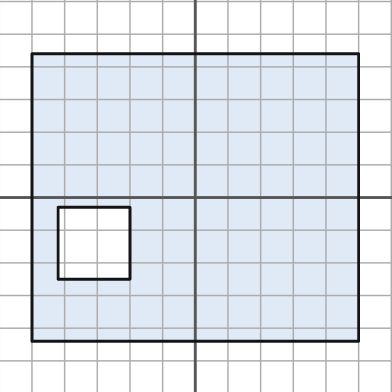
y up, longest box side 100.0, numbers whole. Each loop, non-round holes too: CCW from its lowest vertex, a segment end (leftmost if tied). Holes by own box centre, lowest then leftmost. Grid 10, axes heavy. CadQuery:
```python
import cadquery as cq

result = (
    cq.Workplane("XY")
    .moveTo(-50.0, -44.0)
    .lineTo(50.0, -44.0)
    .lineTo(50.0, 44.0)
    .lineTo(-50.0, 44.0)
    .close()
    .moveTo(-42.0, -25.0)
    .lineTo(-20.0, -25.0)
    .lineTo(-20.0, -3.0)
    .lineTo(-42.0, -3.0)
    .close()
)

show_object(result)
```